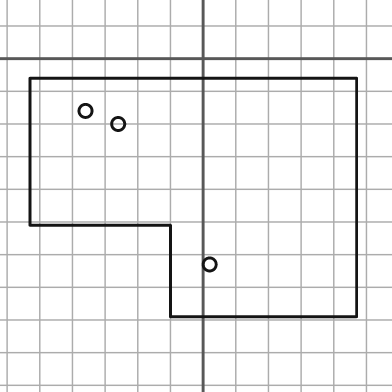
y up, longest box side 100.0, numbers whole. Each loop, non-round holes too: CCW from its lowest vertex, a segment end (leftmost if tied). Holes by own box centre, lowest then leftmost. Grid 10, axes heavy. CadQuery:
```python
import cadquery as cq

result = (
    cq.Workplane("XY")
    .moveTo(-10.0, -79.0)
    .lineTo(47.0, -79.0)
    .lineTo(47.0, -6.0)
    .lineTo(-53.0, -6.0)
    .lineTo(-53.0, -51.0)
    .lineTo(-10.0, -51.0)
    .close()
    .moveTo(2.0, -63.0)
    .circle(2.0)
    .moveTo(-26.0, -20.0)
    .circle(2.0)
    .moveTo(-36.0, -16.0)
    .circle(2.0)
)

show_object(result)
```